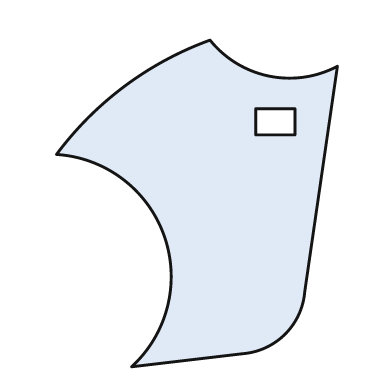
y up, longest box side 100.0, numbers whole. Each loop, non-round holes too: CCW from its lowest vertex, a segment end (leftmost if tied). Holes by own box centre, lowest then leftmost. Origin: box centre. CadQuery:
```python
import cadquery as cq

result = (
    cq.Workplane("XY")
    .moveTo(-20.0, -50.0)
    .lineTo(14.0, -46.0)
    .threePointArc((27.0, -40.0), (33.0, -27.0))
    .lineTo(43.0, 42.0)
    .threePointArc((22.0, 39.0), (4.0, 50.0))
    .threePointArc((-22.0, 36.0), (-43.0, 15.0))
    .threePointArc((-10.0, -10.0), (-20.0, -50.0))
    .close()
    .moveTo(18.0, 21.0)
    .lineTo(30.0, 21.0)
    .lineTo(30.0, 29.0)
    .lineTo(18.0, 29.0)
    .close()
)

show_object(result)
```